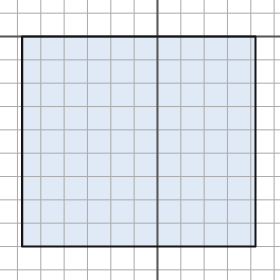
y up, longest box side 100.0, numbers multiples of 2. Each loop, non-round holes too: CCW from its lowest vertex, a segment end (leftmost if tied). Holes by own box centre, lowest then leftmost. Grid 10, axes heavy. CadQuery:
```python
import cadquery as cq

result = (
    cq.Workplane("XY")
    .moveTo(-58.0, -90.0)
    .lineTo(42.0, -90.0)
    .lineTo(42.0, 0.0)
    .lineTo(-58.0, 0.0)
    .close()
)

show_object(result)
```